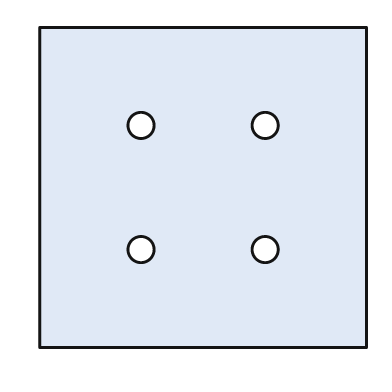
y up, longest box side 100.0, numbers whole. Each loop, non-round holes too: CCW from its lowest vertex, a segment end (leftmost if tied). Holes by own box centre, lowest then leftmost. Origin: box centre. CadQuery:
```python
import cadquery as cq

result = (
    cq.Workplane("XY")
    .moveTo(-50.0, -49.0)
    .lineTo(50.0, -49.0)
    .lineTo(50.0, 49.0)
    .lineTo(-50.0, 49.0)
    .close()
    .moveTo(-19.0, -19.0)
    .circle(4.0)
    .moveTo(19.0, -19.0)
    .circle(4.0)
    .moveTo(-19.0, 19.0)
    .circle(4.0)
    .moveTo(19.0, 19.0)
    .circle(4.0)
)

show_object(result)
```